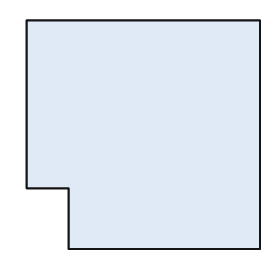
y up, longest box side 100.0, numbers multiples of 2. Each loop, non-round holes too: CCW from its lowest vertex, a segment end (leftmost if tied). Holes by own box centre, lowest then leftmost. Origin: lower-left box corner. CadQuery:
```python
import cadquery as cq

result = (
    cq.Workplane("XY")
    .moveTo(18.0, 0.0)
    .lineTo(100.0, 0.0)
    .lineTo(100.0, 98.0)
    .lineTo(0.0, 98.0)
    .lineTo(0.0, 26.0)
    .lineTo(18.0, 26.0)
    .close()
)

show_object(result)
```